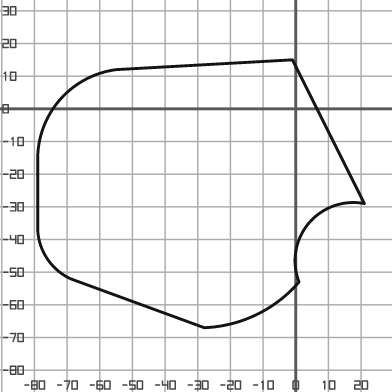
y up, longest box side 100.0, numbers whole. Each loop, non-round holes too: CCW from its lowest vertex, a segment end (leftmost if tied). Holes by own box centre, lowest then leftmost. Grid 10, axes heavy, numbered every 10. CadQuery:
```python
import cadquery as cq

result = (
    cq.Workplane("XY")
    .moveTo(-28.0, -67.0)
    .threePointArc((-12.0, -63.0), (1.0, -53.0))
    .threePointArc((4.0, -35.0), (21.0, -29.0))
    .lineTo(-1.0, 15.0)
    .lineTo(-55.0, 12.0)
    .threePointArc((-72.0, 3.0), (-79.0, -15.0))
    .lineTo(-79.0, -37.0)
    .threePointArc((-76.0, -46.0), (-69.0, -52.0))
    .close()
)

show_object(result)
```